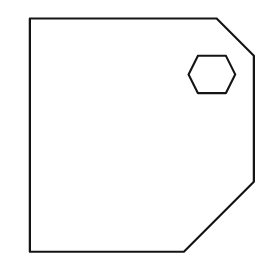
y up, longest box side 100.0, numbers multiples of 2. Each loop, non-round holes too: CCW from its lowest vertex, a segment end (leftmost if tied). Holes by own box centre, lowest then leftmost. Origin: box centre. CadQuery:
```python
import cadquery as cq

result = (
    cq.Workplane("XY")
    .moveTo(-48.0, -50.0)
    .lineTo(18.0, -50.0)
    .lineTo(48.0, -20.0)
    .lineTo(48.0, 34.0)
    .lineTo(32.0, 50.0)
    .lineTo(-48.0, 50.0)
    .close()
    .moveTo(24.0, 18.0)
    .lineTo(36.0, 18.0)
    .lineTo(40.0, 26.0)
    .lineTo(36.0, 34.0)
    .lineTo(24.0, 34.0)
    .lineTo(20.0, 26.0)
    .close()
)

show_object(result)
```